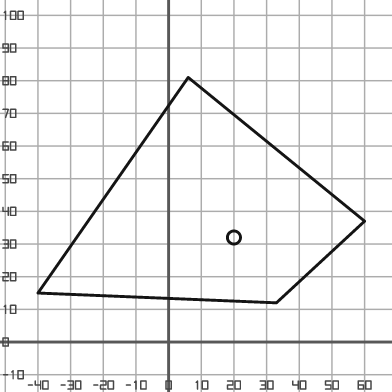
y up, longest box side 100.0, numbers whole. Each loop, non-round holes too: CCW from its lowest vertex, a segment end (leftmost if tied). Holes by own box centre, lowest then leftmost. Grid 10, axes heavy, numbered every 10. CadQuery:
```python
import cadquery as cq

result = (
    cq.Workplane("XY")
    .moveTo(33.0, 12.0)
    .lineTo(60.0, 37.0)
    .lineTo(6.0, 81.0)
    .lineTo(-40.0, 15.0)
    .close()
    .moveTo(20.0, 32.0)
    .circle(2.0)
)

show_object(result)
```